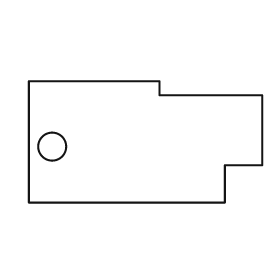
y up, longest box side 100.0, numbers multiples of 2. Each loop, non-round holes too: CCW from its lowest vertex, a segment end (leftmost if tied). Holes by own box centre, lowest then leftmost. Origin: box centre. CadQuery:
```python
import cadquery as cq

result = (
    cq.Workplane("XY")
    .moveTo(-50.0, -26.0)
    .lineTo(34.0, -26.0)
    .lineTo(34.0, -10.0)
    .lineTo(50.0, -10.0)
    .lineTo(50.0, 20.0)
    .lineTo(6.0, 20.0)
    .lineTo(6.0, 26.0)
    .lineTo(-50.0, 26.0)
    .close()
    .moveTo(-40.0, -2.0)
    .circle(6.0)
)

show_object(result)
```